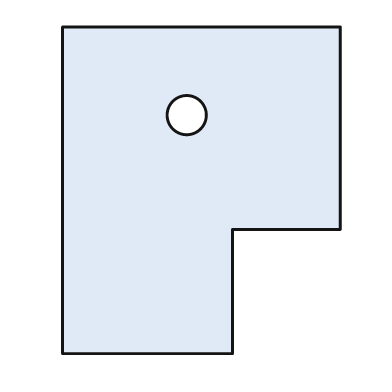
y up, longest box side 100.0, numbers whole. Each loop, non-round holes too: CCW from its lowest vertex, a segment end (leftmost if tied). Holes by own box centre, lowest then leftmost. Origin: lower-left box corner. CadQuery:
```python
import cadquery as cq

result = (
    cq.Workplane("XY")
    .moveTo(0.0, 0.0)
    .lineTo(52.0, 0.0)
    .lineTo(52.0, 38.0)
    .lineTo(85.0, 38.0)
    .lineTo(85.0, 100.0)
    .lineTo(0.0, 100.0)
    .close()
    .moveTo(38.0, 73.0)
    .circle(6.0)
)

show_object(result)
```